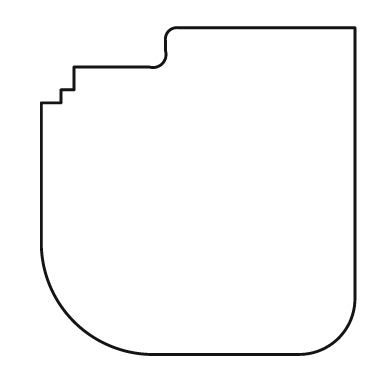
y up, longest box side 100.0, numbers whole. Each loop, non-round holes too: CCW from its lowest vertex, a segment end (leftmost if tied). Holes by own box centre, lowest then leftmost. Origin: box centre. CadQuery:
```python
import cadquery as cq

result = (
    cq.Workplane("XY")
    .moveTo(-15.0, -50.0)
    .lineTo(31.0, -50.0)
    .threePointArc((43.0, -45.0), (48.0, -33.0))
    .lineTo(48.0, 50.0)
    .lineTo(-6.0, 50.0)
    .threePointArc((-9.0, 49.0), (-10.0, 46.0))
    .lineTo(-10.0, 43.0)
    .threePointArc((-11.0, 39.0), (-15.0, 38.0))
    .lineTo(-38.0, 38.0)
    .lineTo(-38.0, 31.0)
    .lineTo(-42.0, 31.0)
    .lineTo(-42.0, 27.0)
    .lineTo(-48.0, 27.0)
    .lineTo(-48.0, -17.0)
    .threePointArc((-38.0, -40.0), (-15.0, -50.0))
    .close()
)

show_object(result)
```